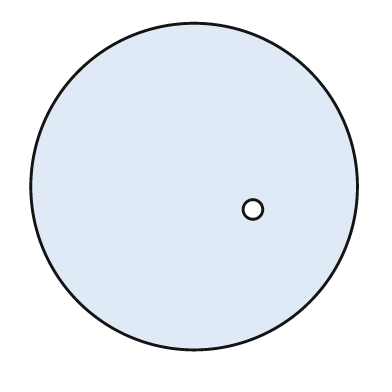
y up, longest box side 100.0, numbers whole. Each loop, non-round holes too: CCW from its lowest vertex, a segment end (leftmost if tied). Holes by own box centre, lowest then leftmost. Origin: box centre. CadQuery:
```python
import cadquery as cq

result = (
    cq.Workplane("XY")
    .moveTo(0.0, 0.0)
    .circle(50.0)
    .moveTo(18.0, -7.0)
    .circle(3.0)
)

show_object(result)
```